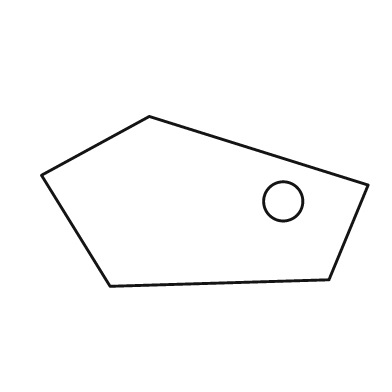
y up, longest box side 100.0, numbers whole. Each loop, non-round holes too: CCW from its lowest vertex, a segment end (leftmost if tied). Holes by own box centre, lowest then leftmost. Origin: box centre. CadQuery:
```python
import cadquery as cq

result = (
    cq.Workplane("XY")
    .moveTo(-29.0, -26.0)
    .lineTo(38.0, -24.0)
    .lineTo(50.0, 5.0)
    .lineTo(-17.0, 26.0)
    .lineTo(-50.0, 8.0)
    .close()
    .moveTo(24.0, 0.0)
    .circle(6.0)
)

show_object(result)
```